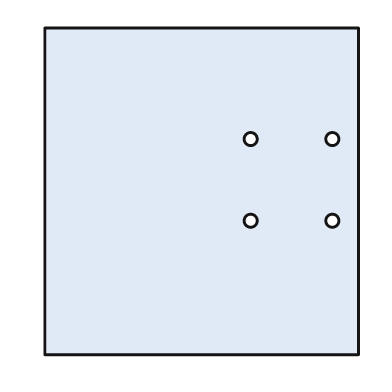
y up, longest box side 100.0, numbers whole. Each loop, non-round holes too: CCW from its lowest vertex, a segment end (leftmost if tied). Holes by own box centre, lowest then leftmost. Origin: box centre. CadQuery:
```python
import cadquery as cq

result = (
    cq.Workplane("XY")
    .moveTo(-48.0, -50.0)
    .lineTo(48.0, -50.0)
    .lineTo(48.0, 50.0)
    .lineTo(-48.0, 50.0)
    .close()
    .moveTo(15.0, -9.0)
    .circle(2.0)
    .moveTo(40.0, -9.0)
    .circle(2.0)
    .moveTo(15.0, 16.0)
    .circle(2.0)
    .moveTo(40.0, 16.0)
    .circle(2.0)
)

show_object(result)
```